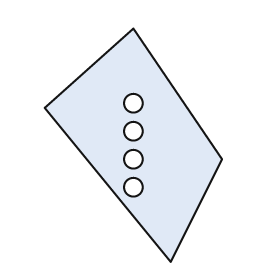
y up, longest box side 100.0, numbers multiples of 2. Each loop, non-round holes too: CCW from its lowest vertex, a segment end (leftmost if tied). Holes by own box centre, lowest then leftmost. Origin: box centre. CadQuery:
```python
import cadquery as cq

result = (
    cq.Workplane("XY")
    .moveTo(16.0, -50.0)
    .lineTo(38.0, -6.0)
    .lineTo(0.0, 50.0)
    .lineTo(-38.0, 16.0)
    .close()
    .moveTo(0.0, -18.0)
    .circle(4.0)
    .moveTo(0.0, -6.0)
    .circle(4.0)
    .moveTo(0.0, 6.0)
    .circle(4.0)
    .moveTo(0.0, 18.0)
    .circle(4.0)
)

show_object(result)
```